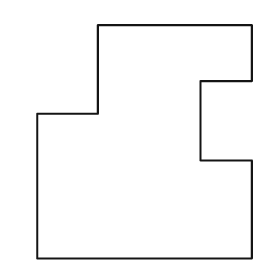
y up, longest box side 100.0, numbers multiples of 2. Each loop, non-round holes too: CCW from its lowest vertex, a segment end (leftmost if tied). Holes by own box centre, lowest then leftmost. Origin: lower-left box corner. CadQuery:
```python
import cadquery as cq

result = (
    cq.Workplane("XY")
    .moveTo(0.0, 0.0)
    .lineTo(92.0, 0.0)
    .lineTo(92.0, 42.0)
    .lineTo(70.0, 42.0)
    .lineTo(70.0, 76.0)
    .lineTo(92.0, 76.0)
    .lineTo(92.0, 100.0)
    .lineTo(26.0, 100.0)
    .lineTo(26.0, 62.0)
    .lineTo(0.0, 62.0)
    .close()
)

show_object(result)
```